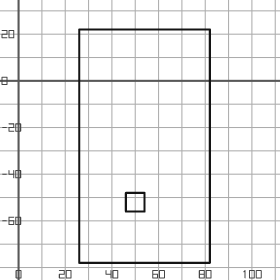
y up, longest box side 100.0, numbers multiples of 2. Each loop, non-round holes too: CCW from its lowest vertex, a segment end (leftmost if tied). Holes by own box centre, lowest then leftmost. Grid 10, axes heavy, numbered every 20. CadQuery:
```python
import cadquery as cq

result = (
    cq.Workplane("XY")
    .moveTo(26.0, -78.0)
    .lineTo(82.0, -78.0)
    .lineTo(82.0, 22.0)
    .lineTo(26.0, 22.0)
    .close()
    .moveTo(46.0, -56.0)
    .lineTo(54.0, -56.0)
    .lineTo(54.0, -48.0)
    .lineTo(46.0, -48.0)
    .close()
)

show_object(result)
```